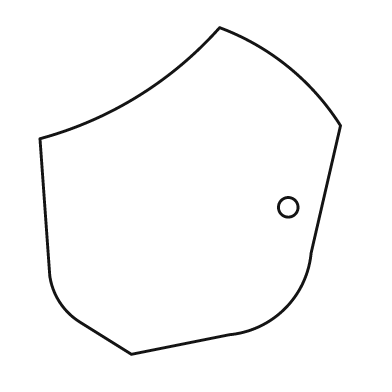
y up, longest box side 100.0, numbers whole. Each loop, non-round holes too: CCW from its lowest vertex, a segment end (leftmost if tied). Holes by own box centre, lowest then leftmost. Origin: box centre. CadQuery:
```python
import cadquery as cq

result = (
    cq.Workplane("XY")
    .moveTo(-18.0, -50.0)
    .lineTo(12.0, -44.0)
    .threePointArc((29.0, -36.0), (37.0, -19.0))
    .lineTo(46.0, 20.0)
    .threePointArc((30.0, 38.0), (9.0, 50.0))
    .threePointArc((-16.0, 29.0), (-46.0, 16.0))
    .lineTo(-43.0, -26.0)
    .threePointArc((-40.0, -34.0), (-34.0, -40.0))
    .close()
    .moveTo(30.0, -5.0)
    .circle(3.0)
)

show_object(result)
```